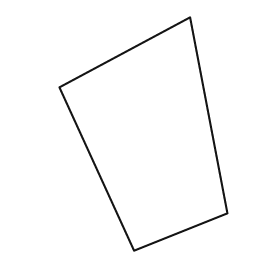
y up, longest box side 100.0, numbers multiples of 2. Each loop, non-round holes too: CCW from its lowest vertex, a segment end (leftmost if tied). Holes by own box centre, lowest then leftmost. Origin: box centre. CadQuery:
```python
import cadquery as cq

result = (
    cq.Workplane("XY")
    .moveTo(-4.0, -50.0)
    .lineTo(36.0, -34.0)
    .lineTo(20.0, 50.0)
    .lineTo(-36.0, 20.0)
    .close()
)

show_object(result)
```